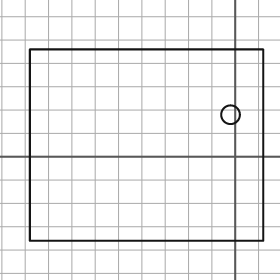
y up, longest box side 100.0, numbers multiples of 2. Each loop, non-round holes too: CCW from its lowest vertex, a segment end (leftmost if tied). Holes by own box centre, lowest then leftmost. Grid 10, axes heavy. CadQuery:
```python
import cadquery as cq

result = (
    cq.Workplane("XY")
    .moveTo(-88.0, -36.0)
    .lineTo(12.0, -36.0)
    .lineTo(12.0, 46.0)
    .lineTo(-88.0, 46.0)
    .close()
    .moveTo(-2.0, 18.0)
    .circle(4.0)
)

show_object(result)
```